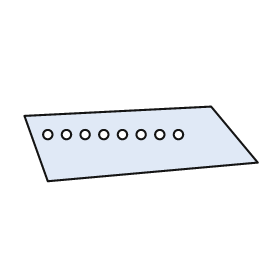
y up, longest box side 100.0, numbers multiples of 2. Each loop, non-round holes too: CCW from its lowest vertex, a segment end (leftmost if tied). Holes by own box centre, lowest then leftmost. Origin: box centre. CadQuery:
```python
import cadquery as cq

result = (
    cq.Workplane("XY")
    .moveTo(-40.0, -16.0)
    .lineTo(50.0, -8.0)
    .lineTo(30.0, 16.0)
    .lineTo(-50.0, 12.0)
    .close()
    .moveTo(-40.0, 4.0)
    .circle(2.0)
    .moveTo(-32.0, 4.0)
    .circle(2.0)
    .moveTo(-24.0, 4.0)
    .circle(2.0)
    .moveTo(-16.0, 4.0)
    .circle(2.0)
    .moveTo(-8.0, 4.0)
    .circle(2.0)
    .moveTo(0.0, 4.0)
    .circle(2.0)
    .moveTo(8.0, 4.0)
    .circle(2.0)
    .moveTo(16.0, 4.0)
    .circle(2.0)
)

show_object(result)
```